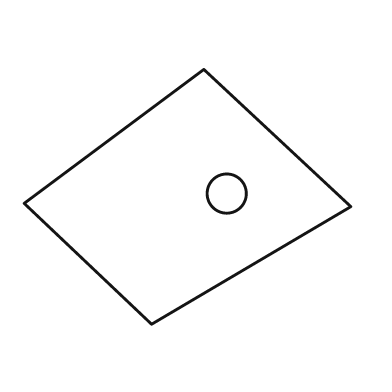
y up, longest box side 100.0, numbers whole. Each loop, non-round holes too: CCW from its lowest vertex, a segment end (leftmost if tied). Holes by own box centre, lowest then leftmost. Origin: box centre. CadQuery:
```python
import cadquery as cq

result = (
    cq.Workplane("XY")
    .moveTo(-11.0, -39.0)
    .lineTo(50.0, -3.0)
    .lineTo(5.0, 39.0)
    .lineTo(-50.0, -2.0)
    .close()
    .moveTo(12.0, 1.0)
    .circle(6.0)
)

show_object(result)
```